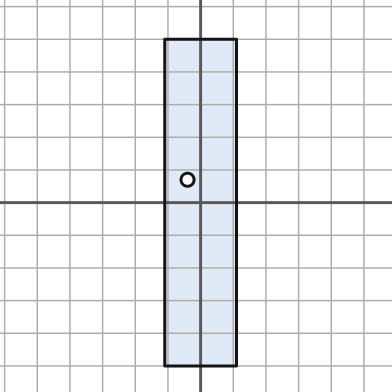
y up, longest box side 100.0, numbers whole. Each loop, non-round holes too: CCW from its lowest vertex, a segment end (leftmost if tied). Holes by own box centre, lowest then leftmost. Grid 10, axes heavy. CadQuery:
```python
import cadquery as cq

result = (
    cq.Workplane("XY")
    .moveTo(-11.0, -50.0)
    .lineTo(11.0, -50.0)
    .lineTo(11.0, 50.0)
    .lineTo(-11.0, 50.0)
    .close()
    .moveTo(-4.0, 7.0)
    .circle(2.0)
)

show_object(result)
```